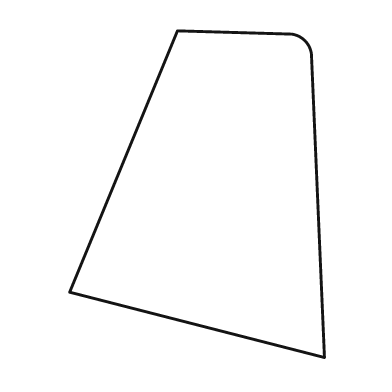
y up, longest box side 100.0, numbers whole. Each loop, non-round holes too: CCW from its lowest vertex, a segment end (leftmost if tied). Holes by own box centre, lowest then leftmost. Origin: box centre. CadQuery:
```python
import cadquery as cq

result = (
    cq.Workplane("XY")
    .moveTo(39.0, -50.0)
    .lineTo(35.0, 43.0)
    .threePointArc((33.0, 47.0), (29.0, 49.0))
    .lineTo(-6.0, 50.0)
    .lineTo(-39.0, -30.0)
    .close()
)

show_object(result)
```